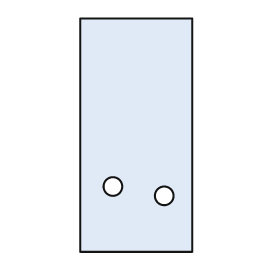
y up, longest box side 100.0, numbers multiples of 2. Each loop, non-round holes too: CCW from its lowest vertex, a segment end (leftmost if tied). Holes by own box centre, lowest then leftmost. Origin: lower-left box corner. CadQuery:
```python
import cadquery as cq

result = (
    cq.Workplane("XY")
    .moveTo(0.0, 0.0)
    .lineTo(48.0, 0.0)
    .lineTo(48.0, 100.0)
    .lineTo(0.0, 100.0)
    .close()
    .moveTo(36.0, 24.0)
    .circle(4.0)
    .moveTo(14.0, 28.0)
    .circle(4.0)
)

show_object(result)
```